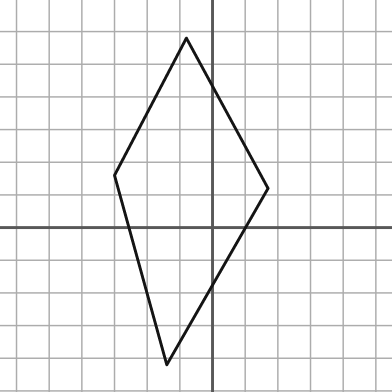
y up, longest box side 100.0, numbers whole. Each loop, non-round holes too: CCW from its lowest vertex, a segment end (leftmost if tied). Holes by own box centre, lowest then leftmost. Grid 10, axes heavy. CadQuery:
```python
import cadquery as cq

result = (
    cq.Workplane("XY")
    .moveTo(-14.0, -42.0)
    .lineTo(17.0, 12.0)
    .lineTo(-8.0, 58.0)
    .lineTo(-30.0, 16.0)
    .close()
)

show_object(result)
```